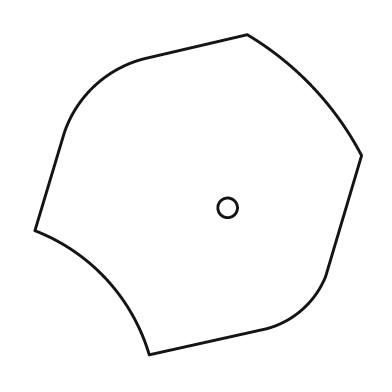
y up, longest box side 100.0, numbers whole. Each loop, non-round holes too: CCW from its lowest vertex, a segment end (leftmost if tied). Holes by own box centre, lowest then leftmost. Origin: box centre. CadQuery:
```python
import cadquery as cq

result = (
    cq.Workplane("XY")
    .moveTo(-15.0, -49.0)
    .lineTo(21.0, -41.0)
    .threePointArc((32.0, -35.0), (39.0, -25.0))
    .lineTo(50.0, 12.0)
    .threePointArc((35.0, 33.0), (15.0, 49.0))
    .lineTo(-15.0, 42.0)
    .threePointArc((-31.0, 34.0), (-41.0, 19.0))
    .lineTo(-50.0, -11.0)
    .threePointArc((-28.0, -26.0), (-15.0, -49.0))
    .close()
    .moveTo(9.0, -4.0)
    .circle(3.0)
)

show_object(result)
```